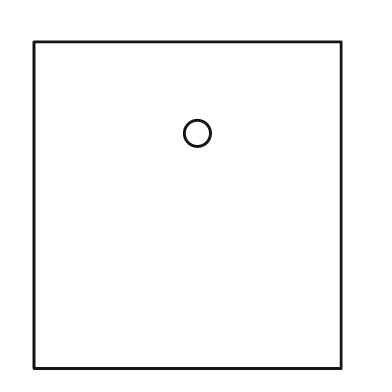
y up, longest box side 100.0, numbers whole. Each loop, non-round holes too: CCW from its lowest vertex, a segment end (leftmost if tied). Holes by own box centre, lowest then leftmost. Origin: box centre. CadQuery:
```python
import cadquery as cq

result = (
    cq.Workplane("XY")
    .moveTo(-47.0, -50.0)
    .lineTo(47.0, -50.0)
    .lineTo(47.0, 50.0)
    .lineTo(-47.0, 50.0)
    .close()
    .moveTo(3.0, 22.0)
    .circle(4.0)
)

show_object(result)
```